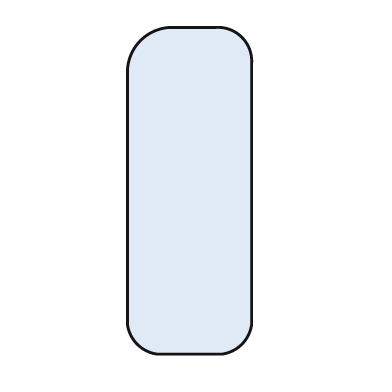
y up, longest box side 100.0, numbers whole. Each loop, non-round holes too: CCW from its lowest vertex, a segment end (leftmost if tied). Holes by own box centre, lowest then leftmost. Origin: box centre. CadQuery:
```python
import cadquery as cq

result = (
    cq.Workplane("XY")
    .moveTo(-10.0, -50.0)
    .lineTo(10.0, -50.0)
    .threePointArc((16.0, -47.0), (19.0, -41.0))
    .lineTo(19.0, 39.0)
    .threePointArc((16.0, 47.0), (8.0, 50.0))
    .lineTo(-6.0, 50.0)
    .threePointArc((-15.0, 46.0), (-19.0, 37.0))
    .lineTo(-19.0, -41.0)
    .threePointArc((-16.0, -47.0), (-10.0, -50.0))
    .close()
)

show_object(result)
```